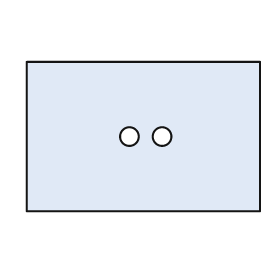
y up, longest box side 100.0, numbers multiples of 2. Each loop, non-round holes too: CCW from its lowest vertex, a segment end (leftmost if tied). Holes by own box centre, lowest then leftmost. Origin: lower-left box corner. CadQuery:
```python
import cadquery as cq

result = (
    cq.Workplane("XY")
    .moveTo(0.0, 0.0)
    .lineTo(100.0, 0.0)
    .lineTo(100.0, 64.0)
    .lineTo(0.0, 64.0)
    .close()
    .moveTo(44.0, 32.0)
    .circle(4.0)
    .moveTo(58.0, 32.0)
    .circle(4.0)
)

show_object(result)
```